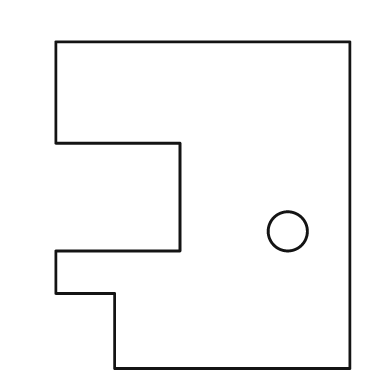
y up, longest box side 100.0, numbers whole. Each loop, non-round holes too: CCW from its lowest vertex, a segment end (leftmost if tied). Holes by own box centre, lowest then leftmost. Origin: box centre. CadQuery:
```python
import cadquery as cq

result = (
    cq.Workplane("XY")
    .moveTo(-27.0, -50.0)
    .lineTo(45.0, -50.0)
    .lineTo(45.0, 50.0)
    .lineTo(-45.0, 50.0)
    .lineTo(-45.0, 19.0)
    .lineTo(-7.0, 19.0)
    .lineTo(-7.0, -14.0)
    .lineTo(-45.0, -14.0)
    .lineTo(-45.0, -27.0)
    .lineTo(-27.0, -27.0)
    .close()
    .moveTo(26.0, -8.0)
    .circle(6.0)
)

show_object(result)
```